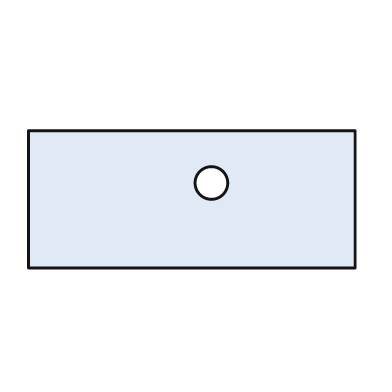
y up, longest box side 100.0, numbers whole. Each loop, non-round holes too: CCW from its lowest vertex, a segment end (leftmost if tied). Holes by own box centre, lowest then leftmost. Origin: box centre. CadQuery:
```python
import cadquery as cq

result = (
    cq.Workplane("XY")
    .moveTo(-50.0, -21.0)
    .lineTo(50.0, -21.0)
    .lineTo(50.0, 21.0)
    .lineTo(-50.0, 21.0)
    .close()
    .moveTo(6.0, 5.0)
    .circle(5.0)
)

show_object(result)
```